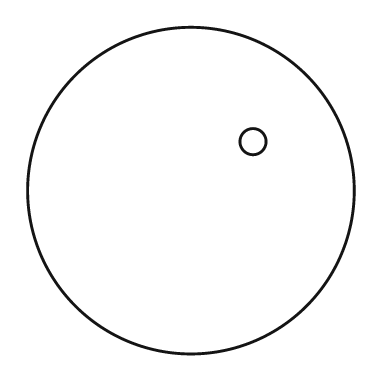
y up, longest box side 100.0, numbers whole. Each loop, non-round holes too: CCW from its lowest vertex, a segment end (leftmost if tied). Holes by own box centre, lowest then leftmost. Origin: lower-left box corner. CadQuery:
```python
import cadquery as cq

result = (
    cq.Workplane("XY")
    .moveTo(50.0, 50.0)
    .circle(50.0)
    .moveTo(69.0, 65.0)
    .circle(4.0)
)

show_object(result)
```